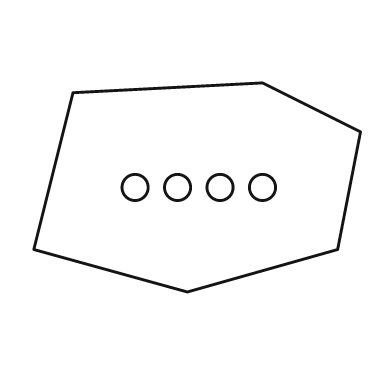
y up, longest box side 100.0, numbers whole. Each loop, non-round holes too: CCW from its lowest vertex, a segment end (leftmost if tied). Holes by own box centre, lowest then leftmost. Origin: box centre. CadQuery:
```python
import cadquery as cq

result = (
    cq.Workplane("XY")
    .moveTo(-3.0, -32.0)
    .lineTo(43.0, -19.0)
    .lineTo(50.0, 17.0)
    .lineTo(20.0, 32.0)
    .lineTo(-38.0, 29.0)
    .lineTo(-50.0, -19.0)
    .close()
    .moveTo(-19.0, 0.0)
    .circle(4.0)
    .moveTo(-6.0, 0.0)
    .circle(4.0)
    .moveTo(7.0, 0.0)
    .circle(4.0)
    .moveTo(20.0, 0.0)
    .circle(4.0)
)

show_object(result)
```